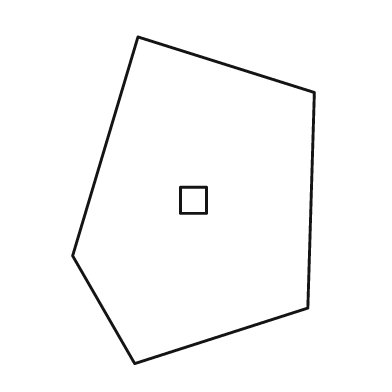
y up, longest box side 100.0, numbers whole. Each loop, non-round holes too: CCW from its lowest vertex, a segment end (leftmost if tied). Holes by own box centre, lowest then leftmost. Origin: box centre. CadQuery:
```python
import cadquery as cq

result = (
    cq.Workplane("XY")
    .moveTo(-18.0, -50.0)
    .lineTo(35.0, -33.0)
    .lineTo(37.0, 33.0)
    .lineTo(-17.0, 50.0)
    .lineTo(-37.0, -17.0)
    .close()
    .moveTo(-4.0, -4.0)
    .lineTo(4.0, -4.0)
    .lineTo(4.0, 4.0)
    .lineTo(-4.0, 4.0)
    .close()
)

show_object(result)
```